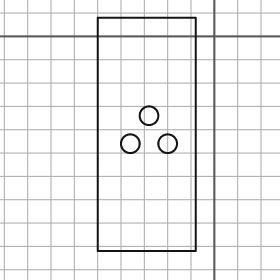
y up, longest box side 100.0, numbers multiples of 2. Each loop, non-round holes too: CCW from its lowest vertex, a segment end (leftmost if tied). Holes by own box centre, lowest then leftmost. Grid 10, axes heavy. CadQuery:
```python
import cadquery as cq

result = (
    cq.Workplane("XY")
    .moveTo(-50.0, -92.0)
    .lineTo(-8.0, -92.0)
    .lineTo(-8.0, 8.0)
    .lineTo(-50.0, 8.0)
    .close()
    .moveTo(-36.0, -46.0)
    .circle(4.0)
    .moveTo(-20.0, -46.0)
    .circle(4.0)
    .moveTo(-28.0, -34.0)
    .circle(4.0)
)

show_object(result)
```